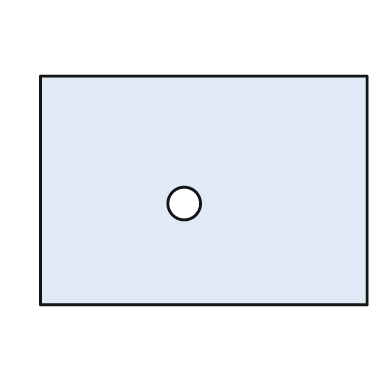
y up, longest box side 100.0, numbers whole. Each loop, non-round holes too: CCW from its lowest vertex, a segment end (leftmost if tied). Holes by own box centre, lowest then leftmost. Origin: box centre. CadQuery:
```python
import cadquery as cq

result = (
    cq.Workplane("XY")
    .moveTo(-50.0, -35.0)
    .lineTo(50.0, -35.0)
    .lineTo(50.0, 35.0)
    .lineTo(-50.0, 35.0)
    .close()
    .moveTo(-6.0, -4.0)
    .circle(5.0)
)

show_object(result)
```